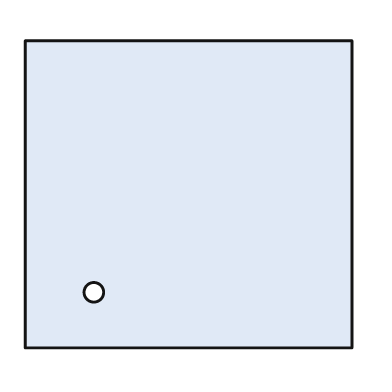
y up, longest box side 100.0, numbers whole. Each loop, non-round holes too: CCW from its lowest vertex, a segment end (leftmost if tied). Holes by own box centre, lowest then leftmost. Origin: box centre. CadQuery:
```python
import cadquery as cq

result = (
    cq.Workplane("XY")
    .moveTo(-50.0, -47.0)
    .lineTo(50.0, -47.0)
    .lineTo(50.0, 47.0)
    .lineTo(-50.0, 47.0)
    .close()
    .moveTo(-29.0, -30.0)
    .circle(3.0)
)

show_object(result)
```